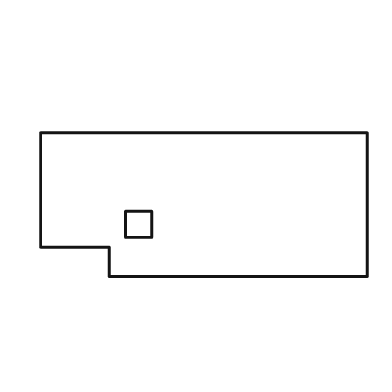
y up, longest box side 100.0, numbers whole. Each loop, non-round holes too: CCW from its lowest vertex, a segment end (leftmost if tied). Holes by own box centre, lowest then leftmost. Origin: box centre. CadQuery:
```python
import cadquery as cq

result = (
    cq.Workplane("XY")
    .moveTo(-29.0, -22.0)
    .lineTo(50.0, -22.0)
    .lineTo(50.0, 22.0)
    .lineTo(-50.0, 22.0)
    .lineTo(-50.0, -13.0)
    .lineTo(-29.0, -13.0)
    .close()
    .moveTo(-24.0, -10.0)
    .lineTo(-16.0, -10.0)
    .lineTo(-16.0, -2.0)
    .lineTo(-24.0, -2.0)
    .close()
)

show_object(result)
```